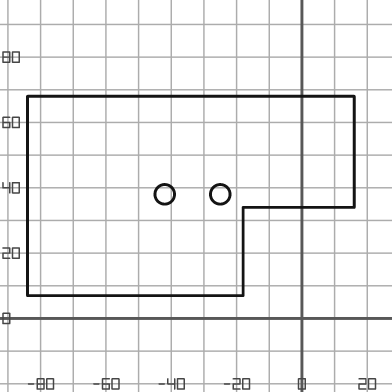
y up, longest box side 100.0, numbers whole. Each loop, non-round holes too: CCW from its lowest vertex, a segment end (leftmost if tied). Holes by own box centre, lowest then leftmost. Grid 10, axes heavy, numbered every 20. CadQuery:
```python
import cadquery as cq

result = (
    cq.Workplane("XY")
    .moveTo(-84.0, 7.0)
    .lineTo(-18.0, 7.0)
    .lineTo(-18.0, 34.0)
    .lineTo(16.0, 34.0)
    .lineTo(16.0, 68.0)
    .lineTo(-84.0, 68.0)
    .close()
    .moveTo(-42.0, 38.0)
    .circle(3.0)
    .moveTo(-25.0, 38.0)
    .circle(3.0)
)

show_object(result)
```